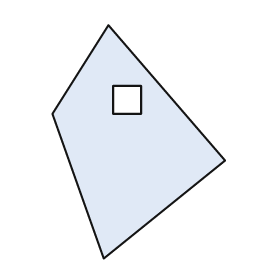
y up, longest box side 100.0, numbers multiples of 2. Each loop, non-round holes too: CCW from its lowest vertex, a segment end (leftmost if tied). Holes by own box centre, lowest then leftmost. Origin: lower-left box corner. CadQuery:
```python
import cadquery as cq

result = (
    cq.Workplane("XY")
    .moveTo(22.0, 0.0)
    .lineTo(74.0, 42.0)
    .lineTo(24.0, 100.0)
    .lineTo(0.0, 62.0)
    .close()
    .moveTo(26.0, 62.0)
    .lineTo(38.0, 62.0)
    .lineTo(38.0, 74.0)
    .lineTo(26.0, 74.0)
    .close()
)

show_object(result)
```